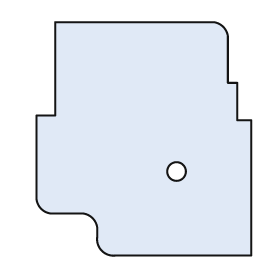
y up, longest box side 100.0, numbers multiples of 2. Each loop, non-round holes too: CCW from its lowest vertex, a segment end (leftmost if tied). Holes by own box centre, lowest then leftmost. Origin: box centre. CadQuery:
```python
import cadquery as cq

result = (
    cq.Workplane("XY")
    .moveTo(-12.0, -50.0)
    .lineTo(46.0, -50.0)
    .lineTo(46.0, 8.0)
    .lineTo(40.0, 8.0)
    .lineTo(40.0, 24.0)
    .lineTo(36.0, 24.0)
    .lineTo(36.0, 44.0)
    .threePointArc((34.0, 48.0), (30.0, 50.0))
    .lineTo(-38.0, 50.0)
    .lineTo(-38.0, 10.0)
    .lineTo(-46.0, 10.0)
    .lineTo(-46.0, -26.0)
    .threePointArc((-44.0, -30.0), (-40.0, -32.0))
    .lineTo(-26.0, -32.0)
    .threePointArc((-22.0, -34.0), (-20.0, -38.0))
    .lineTo(-20.0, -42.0)
    .threePointArc((-18.0, -48.0), (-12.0, -50.0))
    .close()
    .moveTo(14.0, -14.0)
    .circle(4.0)
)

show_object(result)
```